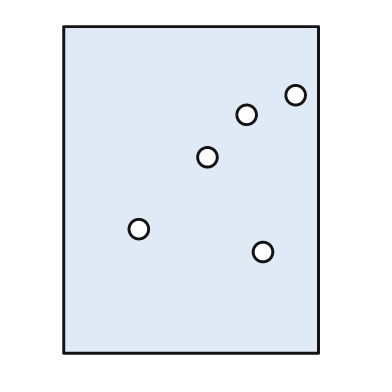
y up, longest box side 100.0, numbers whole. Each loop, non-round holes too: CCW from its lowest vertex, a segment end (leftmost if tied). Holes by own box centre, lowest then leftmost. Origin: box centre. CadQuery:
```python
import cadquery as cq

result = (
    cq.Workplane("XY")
    .moveTo(-39.0, -50.0)
    .lineTo(39.0, -50.0)
    .lineTo(39.0, 50.0)
    .lineTo(-39.0, 50.0)
    .close()
    .moveTo(22.0, -19.0)
    .circle(3.0)
    .moveTo(-16.0, -12.0)
    .circle(3.0)
    .moveTo(5.0, 10.0)
    .circle(3.0)
    .moveTo(17.0, 23.0)
    .circle(3.0)
    .moveTo(32.0, 29.0)
    .circle(3.0)
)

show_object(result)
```